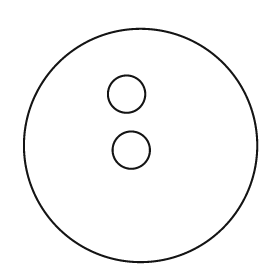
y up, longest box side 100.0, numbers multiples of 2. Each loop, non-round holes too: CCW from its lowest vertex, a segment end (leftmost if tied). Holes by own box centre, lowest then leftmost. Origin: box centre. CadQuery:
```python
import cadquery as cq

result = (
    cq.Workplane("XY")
    .moveTo(0.0, 0.0)
    .circle(50.0)
    .moveTo(-4.0, -2.0)
    .circle(8.0)
    .moveTo(-6.0, 22.0)
    .circle(8.0)
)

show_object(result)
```